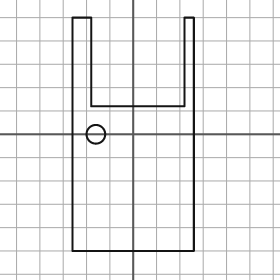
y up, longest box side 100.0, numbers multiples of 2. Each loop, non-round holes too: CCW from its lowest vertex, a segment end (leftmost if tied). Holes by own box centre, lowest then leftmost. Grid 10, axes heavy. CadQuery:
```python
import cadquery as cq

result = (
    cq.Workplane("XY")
    .moveTo(-26.0, -50.0)
    .lineTo(26.0, -50.0)
    .lineTo(26.0, 50.0)
    .lineTo(22.0, 50.0)
    .lineTo(22.0, 12.0)
    .lineTo(-18.0, 12.0)
    .lineTo(-18.0, 50.0)
    .lineTo(-26.0, 50.0)
    .close()
    .moveTo(-16.0, 0.0)
    .circle(4.0)
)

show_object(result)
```